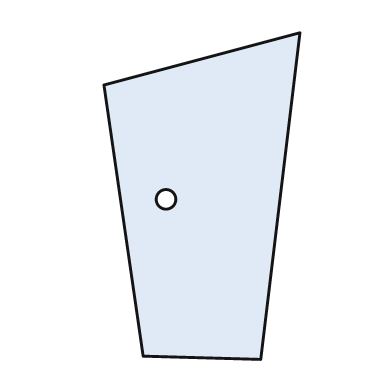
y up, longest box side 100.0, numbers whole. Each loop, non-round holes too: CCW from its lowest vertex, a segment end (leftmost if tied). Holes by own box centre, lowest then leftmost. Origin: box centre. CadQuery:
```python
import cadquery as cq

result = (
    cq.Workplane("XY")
    .moveTo(18.0, -50.0)
    .lineTo(30.0, 50.0)
    .lineTo(-30.0, 34.0)
    .lineTo(-18.0, -49.0)
    .close()
    .moveTo(-11.0, -1.0)
    .circle(3.0)
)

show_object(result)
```